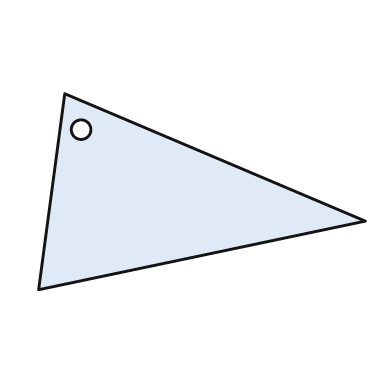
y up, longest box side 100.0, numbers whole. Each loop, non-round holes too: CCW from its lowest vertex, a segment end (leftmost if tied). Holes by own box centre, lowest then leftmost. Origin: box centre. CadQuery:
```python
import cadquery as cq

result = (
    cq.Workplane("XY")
    .moveTo(-50.0, -30.0)
    .lineTo(50.0, -9.0)
    .lineTo(-42.0, 30.0)
    .close()
    .moveTo(-37.0, 19.0)
    .circle(3.0)
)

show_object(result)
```